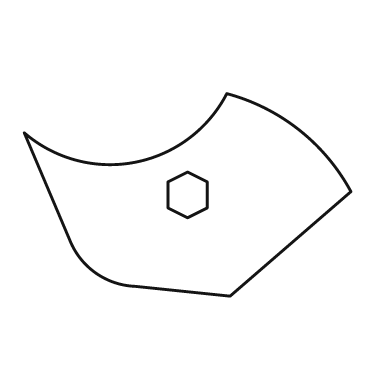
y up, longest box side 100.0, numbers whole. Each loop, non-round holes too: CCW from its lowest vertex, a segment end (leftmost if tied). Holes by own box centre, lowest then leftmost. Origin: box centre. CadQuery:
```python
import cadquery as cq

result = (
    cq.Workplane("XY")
    .moveTo(13.0, -31.0)
    .lineTo(50.0, 1.0)
    .threePointArc((34.0, 20.0), (12.0, 31.0))
    .threePointArc((-16.0, 10.0), (-50.0, 19.0))
    .lineTo(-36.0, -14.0)
    .threePointArc((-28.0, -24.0), (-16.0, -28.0))
    .close()
    .moveTo(0.0, -7.0)
    .lineTo(6.0, -4.0)
    .lineTo(6.0, 4.0)
    .lineTo(0.0, 7.0)
    .lineTo(-6.0, 4.0)
    .lineTo(-6.0, -4.0)
    .close()
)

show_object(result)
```